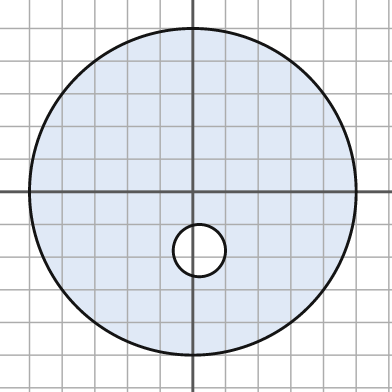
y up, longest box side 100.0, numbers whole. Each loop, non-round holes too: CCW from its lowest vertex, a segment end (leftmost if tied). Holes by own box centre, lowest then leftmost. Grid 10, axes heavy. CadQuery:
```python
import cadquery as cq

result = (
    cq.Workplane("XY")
    .moveTo(0.0, 0.0)
    .circle(50.0)
    .moveTo(2.0, -18.0)
    .circle(8.0)
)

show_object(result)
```